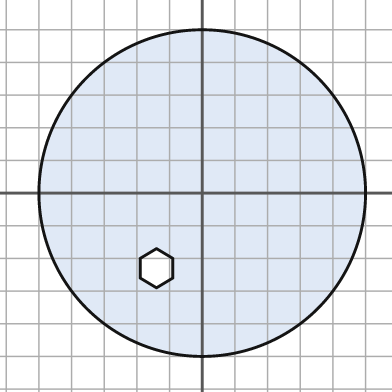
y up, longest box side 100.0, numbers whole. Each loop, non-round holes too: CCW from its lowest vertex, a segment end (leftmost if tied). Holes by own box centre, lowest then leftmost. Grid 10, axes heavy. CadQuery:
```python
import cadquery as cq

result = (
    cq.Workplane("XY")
    .moveTo(0.0, 0.0)
    .circle(50.0)
    .moveTo(-14.0, -29.0)
    .lineTo(-9.0, -26.0)
    .lineTo(-9.0, -20.0)
    .lineTo(-14.0, -17.0)
    .lineTo(-19.0, -20.0)
    .lineTo(-19.0, -26.0)
    .close()
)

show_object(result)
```